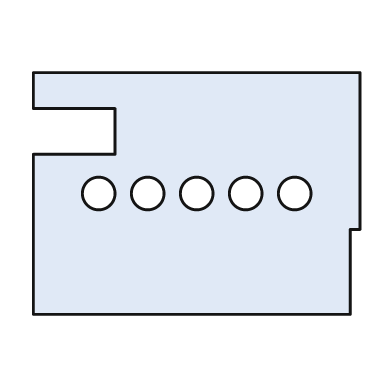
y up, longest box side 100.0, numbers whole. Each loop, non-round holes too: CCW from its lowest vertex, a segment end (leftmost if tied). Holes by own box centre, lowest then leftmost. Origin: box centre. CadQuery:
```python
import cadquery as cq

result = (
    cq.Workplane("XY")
    .moveTo(-50.0, -37.0)
    .lineTo(47.0, -37.0)
    .lineTo(47.0, -11.0)
    .lineTo(50.0, -11.0)
    .lineTo(50.0, 37.0)
    .lineTo(-50.0, 37.0)
    .lineTo(-50.0, 26.0)
    .lineTo(-25.0, 26.0)
    .lineTo(-25.0, 12.0)
    .lineTo(-50.0, 12.0)
    .close()
    .moveTo(-30.0, 0.0)
    .circle(5.0)
    .moveTo(-15.0, 0.0)
    .circle(5.0)
    .moveTo(0.0, 0.0)
    .circle(5.0)
    .moveTo(15.0, 0.0)
    .circle(5.0)
    .moveTo(30.0, 0.0)
    .circle(5.0)
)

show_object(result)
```